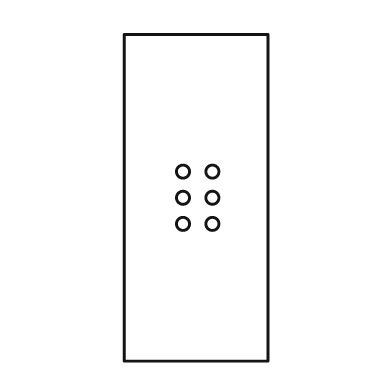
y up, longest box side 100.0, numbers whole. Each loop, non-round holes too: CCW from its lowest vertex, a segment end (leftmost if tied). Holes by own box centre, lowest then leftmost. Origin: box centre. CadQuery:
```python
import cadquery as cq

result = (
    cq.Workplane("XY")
    .moveTo(-22.0, -50.0)
    .lineTo(22.0, -50.0)
    .lineTo(22.0, 50.0)
    .lineTo(-22.0, 50.0)
    .close()
    .moveTo(-4.0, -8.0)
    .circle(2.0)
    .moveTo(5.0, -8.0)
    .circle(2.0)
    .moveTo(-4.0, 0.0)
    .circle(2.0)
    .moveTo(5.0, 0.0)
    .circle(2.0)
    .moveTo(-4.0, 8.0)
    .circle(2.0)
    .moveTo(5.0, 8.0)
    .circle(2.0)
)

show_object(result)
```